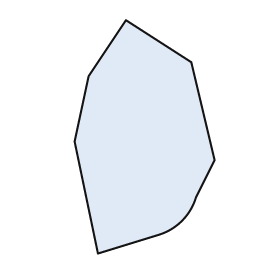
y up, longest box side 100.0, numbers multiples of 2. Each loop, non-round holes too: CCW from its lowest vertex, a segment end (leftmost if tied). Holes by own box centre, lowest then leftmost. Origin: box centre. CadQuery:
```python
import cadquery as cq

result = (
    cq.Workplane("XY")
    .moveTo(-20.0, -50.0)
    .lineTo(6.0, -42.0)
    .threePointArc((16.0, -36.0), (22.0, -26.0))
    .lineTo(30.0, -10.0)
    .lineTo(20.0, 32.0)
    .lineTo(-8.0, 50.0)
    .lineTo(-24.0, 26.0)
    .lineTo(-30.0, -2.0)
    .close()
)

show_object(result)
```